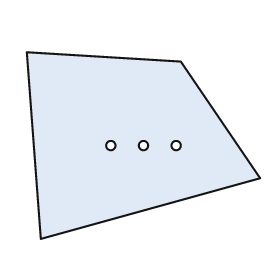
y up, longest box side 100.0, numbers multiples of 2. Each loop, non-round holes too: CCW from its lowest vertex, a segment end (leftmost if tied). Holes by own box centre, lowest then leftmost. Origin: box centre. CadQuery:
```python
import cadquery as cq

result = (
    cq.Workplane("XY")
    .moveTo(-44.0, -40.0)
    .lineTo(50.0, -14.0)
    .lineTo(16.0, 36.0)
    .lineTo(-50.0, 40.0)
    .close()
    .moveTo(-14.0, 0.0)
    .circle(2.0)
    .moveTo(0.0, 0.0)
    .circle(2.0)
    .moveTo(14.0, 0.0)
    .circle(2.0)
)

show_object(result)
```